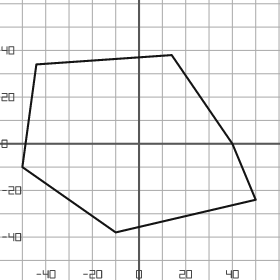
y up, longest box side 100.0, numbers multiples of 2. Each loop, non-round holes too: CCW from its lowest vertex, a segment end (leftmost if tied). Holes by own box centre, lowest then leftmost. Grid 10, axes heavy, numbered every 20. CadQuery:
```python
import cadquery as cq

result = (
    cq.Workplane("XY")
    .moveTo(-10.0, -38.0)
    .lineTo(50.0, -24.0)
    .lineTo(40.0, 0.0)
    .lineTo(14.0, 38.0)
    .lineTo(-44.0, 34.0)
    .lineTo(-50.0, -10.0)
    .close()
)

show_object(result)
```